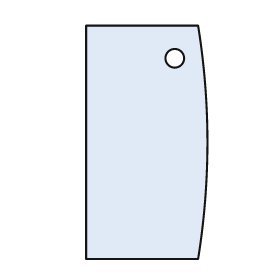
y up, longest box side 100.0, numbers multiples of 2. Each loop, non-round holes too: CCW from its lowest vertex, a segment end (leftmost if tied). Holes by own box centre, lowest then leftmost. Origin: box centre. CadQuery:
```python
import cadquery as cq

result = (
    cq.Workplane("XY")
    .moveTo(-26.0, -50.0)
    .lineTo(22.0, -50.0)
    .threePointArc((26.0, 0.0), (22.0, 50.0))
    .lineTo(-26.0, 50.0)
    .close()
    .moveTo(12.0, 36.0)
    .circle(4.0)
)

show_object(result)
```